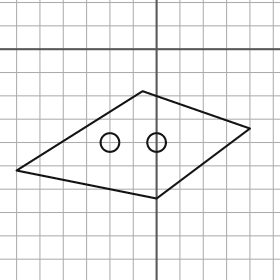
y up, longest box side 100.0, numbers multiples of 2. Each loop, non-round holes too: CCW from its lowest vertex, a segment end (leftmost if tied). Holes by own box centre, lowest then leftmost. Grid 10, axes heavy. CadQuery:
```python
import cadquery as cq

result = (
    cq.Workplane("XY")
    .moveTo(0.0, -64.0)
    .lineTo(40.0, -34.0)
    .lineTo(-6.0, -18.0)
    .lineTo(-60.0, -52.0)
    .close()
    .moveTo(-20.0, -40.0)
    .circle(4.0)
    .moveTo(0.0, -40.0)
    .circle(4.0)
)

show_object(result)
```